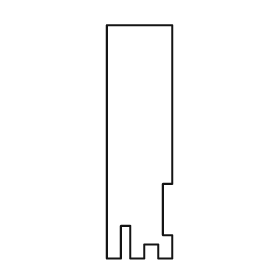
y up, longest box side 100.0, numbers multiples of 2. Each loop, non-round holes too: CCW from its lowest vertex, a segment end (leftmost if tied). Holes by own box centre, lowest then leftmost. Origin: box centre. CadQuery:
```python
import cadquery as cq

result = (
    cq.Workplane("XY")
    .moveTo(-14.0, -50.0)
    .lineTo(-8.0, -50.0)
    .lineTo(-8.0, -36.0)
    .lineTo(-4.0, -36.0)
    .lineTo(-4.0, -50.0)
    .lineTo(2.0, -50.0)
    .lineTo(2.0, -44.0)
    .lineTo(8.0, -44.0)
    .lineTo(8.0, -50.0)
    .lineTo(14.0, -50.0)
    .lineTo(14.0, -40.0)
    .lineTo(10.0, -40.0)
    .lineTo(10.0, -18.0)
    .lineTo(14.0, -18.0)
    .lineTo(14.0, 50.0)
    .lineTo(-14.0, 50.0)
    .close()
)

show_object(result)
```